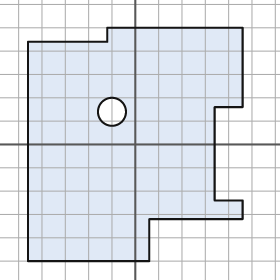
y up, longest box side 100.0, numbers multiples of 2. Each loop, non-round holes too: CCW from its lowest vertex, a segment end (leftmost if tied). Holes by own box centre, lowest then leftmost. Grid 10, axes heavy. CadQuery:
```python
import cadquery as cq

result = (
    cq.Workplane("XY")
    .moveTo(-46.0, -50.0)
    .lineTo(6.0, -50.0)
    .lineTo(6.0, -32.0)
    .lineTo(46.0, -32.0)
    .lineTo(46.0, -24.0)
    .lineTo(34.0, -24.0)
    .lineTo(34.0, 16.0)
    .lineTo(46.0, 16.0)
    .lineTo(46.0, 50.0)
    .lineTo(-12.0, 50.0)
    .lineTo(-12.0, 44.0)
    .lineTo(-46.0, 44.0)
    .close()
    .moveTo(-10.0, 14.0)
    .circle(6.0)
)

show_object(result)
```